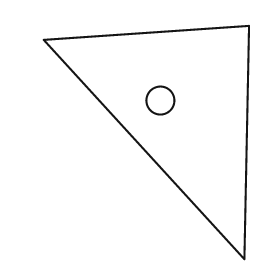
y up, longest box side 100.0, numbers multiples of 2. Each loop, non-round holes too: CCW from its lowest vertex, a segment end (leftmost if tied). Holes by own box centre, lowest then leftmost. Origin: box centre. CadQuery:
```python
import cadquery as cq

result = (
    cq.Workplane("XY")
    .moveTo(42.0, -50.0)
    .lineTo(44.0, 50.0)
    .lineTo(-44.0, 44.0)
    .close()
    .moveTo(6.0, 18.0)
    .circle(6.0)
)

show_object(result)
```